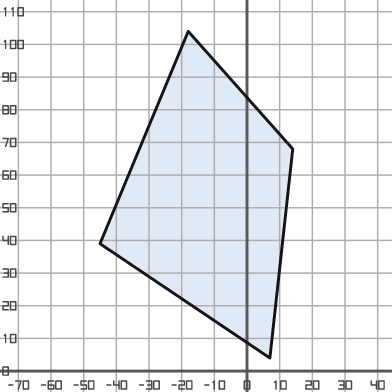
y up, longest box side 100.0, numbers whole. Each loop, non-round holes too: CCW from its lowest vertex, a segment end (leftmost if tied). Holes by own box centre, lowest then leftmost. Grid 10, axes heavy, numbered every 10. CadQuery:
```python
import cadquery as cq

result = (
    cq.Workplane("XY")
    .moveTo(7.0, 4.0)
    .lineTo(14.0, 68.0)
    .lineTo(-18.0, 104.0)
    .lineTo(-45.0, 39.0)
    .close()
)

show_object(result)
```